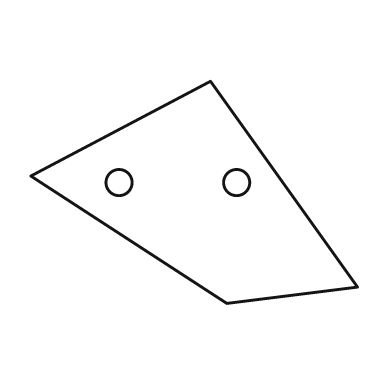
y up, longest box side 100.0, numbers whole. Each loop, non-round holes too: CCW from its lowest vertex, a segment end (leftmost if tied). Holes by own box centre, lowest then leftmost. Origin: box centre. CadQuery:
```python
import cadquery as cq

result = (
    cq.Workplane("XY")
    .moveTo(10.0, -34.0)
    .lineTo(50.0, -29.0)
    .lineTo(5.0, 34.0)
    .lineTo(-50.0, 5.0)
    .close()
    .moveTo(-23.0, 3.0)
    .circle(4.0)
    .moveTo(13.0, 3.0)
    .circle(4.0)
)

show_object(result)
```